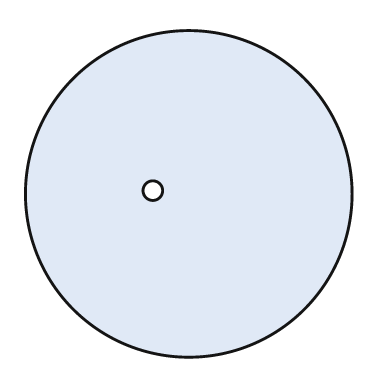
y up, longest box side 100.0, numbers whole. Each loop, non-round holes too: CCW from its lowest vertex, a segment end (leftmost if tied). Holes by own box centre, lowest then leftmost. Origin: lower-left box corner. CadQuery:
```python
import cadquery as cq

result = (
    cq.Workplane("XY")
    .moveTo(50.0, 50.0)
    .circle(50.0)
    .moveTo(39.0, 51.0)
    .circle(3.0)
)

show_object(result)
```